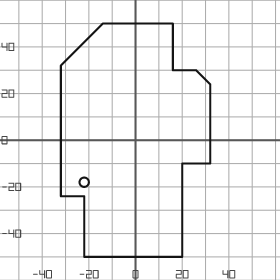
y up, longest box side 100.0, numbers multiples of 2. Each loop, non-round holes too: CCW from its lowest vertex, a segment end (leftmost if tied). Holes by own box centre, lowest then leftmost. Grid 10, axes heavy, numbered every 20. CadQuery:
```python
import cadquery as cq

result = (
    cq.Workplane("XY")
    .moveTo(-22.0, -50.0)
    .lineTo(20.0, -50.0)
    .lineTo(20.0, -10.0)
    .lineTo(32.0, -10.0)
    .lineTo(32.0, 24.0)
    .lineTo(26.0, 30.0)
    .lineTo(16.0, 30.0)
    .lineTo(16.0, 50.0)
    .lineTo(-14.0, 50.0)
    .lineTo(-32.0, 32.0)
    .lineTo(-32.0, -24.0)
    .lineTo(-22.0, -24.0)
    .close()
    .moveTo(-22.0, -18.0)
    .circle(2.0)
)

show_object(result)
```